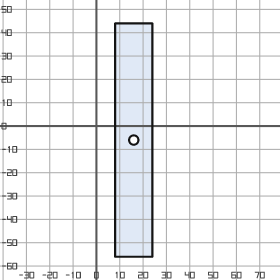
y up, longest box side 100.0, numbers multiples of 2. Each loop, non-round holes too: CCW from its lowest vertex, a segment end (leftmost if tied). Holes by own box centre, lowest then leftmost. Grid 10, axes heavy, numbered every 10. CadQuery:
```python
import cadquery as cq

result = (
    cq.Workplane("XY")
    .moveTo(8.0, -56.0)
    .lineTo(24.0, -56.0)
    .lineTo(24.0, 44.0)
    .lineTo(8.0, 44.0)
    .close()
    .moveTo(16.0, -6.0)
    .circle(2.0)
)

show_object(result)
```